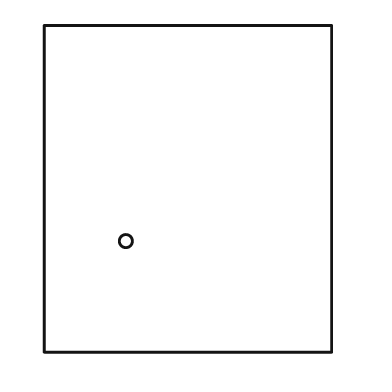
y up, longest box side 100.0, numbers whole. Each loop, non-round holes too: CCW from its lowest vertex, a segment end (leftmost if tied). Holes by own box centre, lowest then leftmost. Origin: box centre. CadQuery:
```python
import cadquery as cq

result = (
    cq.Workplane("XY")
    .moveTo(-44.0, -50.0)
    .lineTo(44.0, -50.0)
    .lineTo(44.0, 50.0)
    .lineTo(-44.0, 50.0)
    .close()
    .moveTo(-19.0, -16.0)
    .circle(2.0)
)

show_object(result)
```